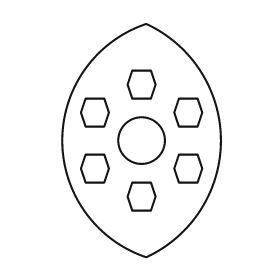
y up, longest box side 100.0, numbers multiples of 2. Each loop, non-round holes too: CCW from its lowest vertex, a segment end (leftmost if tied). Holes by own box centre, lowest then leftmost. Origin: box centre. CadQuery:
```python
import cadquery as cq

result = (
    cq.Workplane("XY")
    .moveTo(2.0, -50.0)
    .threePointArc((34.0, 0.0), (2.0, 50.0))
    .threePointArc((-34.0, 0.0), (2.0, -50.0))
    .close()
    .moveTo(-4.0, -30.0)
    .lineTo(4.0, -30.0)
    .lineTo(6.0, -24.0)
    .lineTo(4.0, -18.0)
    .lineTo(-4.0, -18.0)
    .lineTo(-6.0, -24.0)
    .close()
    .moveTo(-24.0, -18.0)
    .lineTo(-16.0, -18.0)
    .lineTo(-14.0, -12.0)
    .lineTo(-16.0, -6.0)
    .lineTo(-24.0, -6.0)
    .lineTo(-26.0, -12.0)
    .close()
    .moveTo(16.0, -18.0)
    .lineTo(24.0, -18.0)
    .lineTo(26.0, -12.0)
    .lineTo(24.0, -6.0)
    .lineTo(16.0, -6.0)
    .lineTo(14.0, -12.0)
    .close()
    .moveTo(0.0, 0.0)
    .circle(10.0)
    .moveTo(-24.0, 6.0)
    .lineTo(-16.0, 6.0)
    .lineTo(-14.0, 12.0)
    .lineTo(-16.0, 18.0)
    .lineTo(-24.0, 18.0)
    .lineTo(-26.0, 12.0)
    .close()
    .moveTo(16.0, 6.0)
    .lineTo(24.0, 6.0)
    .lineTo(26.0, 12.0)
    .lineTo(24.0, 18.0)
    .lineTo(16.0, 18.0)
    .lineTo(14.0, 12.0)
    .close()
    .moveTo(-4.0, 18.0)
    .lineTo(4.0, 18.0)
    .lineTo(6.0, 24.0)
    .lineTo(4.0, 30.0)
    .lineTo(-4.0, 30.0)
    .lineTo(-6.0, 24.0)
    .close()
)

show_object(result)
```